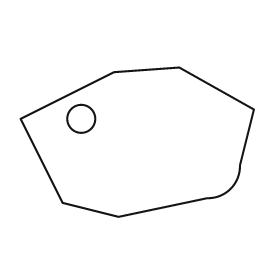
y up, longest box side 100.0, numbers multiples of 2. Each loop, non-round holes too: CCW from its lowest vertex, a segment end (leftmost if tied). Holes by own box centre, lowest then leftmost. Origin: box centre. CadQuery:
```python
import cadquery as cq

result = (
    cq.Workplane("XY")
    .moveTo(-8.0, -32.0)
    .lineTo(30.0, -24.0)
    .threePointArc((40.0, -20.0), (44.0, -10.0))
    .lineTo(50.0, 14.0)
    .lineTo(18.0, 32.0)
    .lineTo(-10.0, 30.0)
    .lineTo(-50.0, 10.0)
    .lineTo(-32.0, -26.0)
    .close()
    .moveTo(-24.0, 10.0)
    .circle(6.0)
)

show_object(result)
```